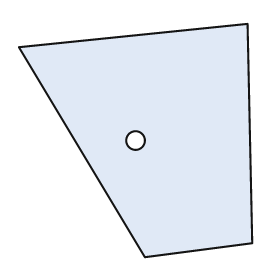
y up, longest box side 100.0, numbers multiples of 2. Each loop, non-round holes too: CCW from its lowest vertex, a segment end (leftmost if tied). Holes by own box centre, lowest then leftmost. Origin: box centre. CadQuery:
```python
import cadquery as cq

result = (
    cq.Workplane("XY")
    .moveTo(4.0, -50.0)
    .lineTo(50.0, -44.0)
    .lineTo(48.0, 50.0)
    .lineTo(-50.0, 40.0)
    .close()
    .moveTo(0.0, 0.0)
    .circle(4.0)
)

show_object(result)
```